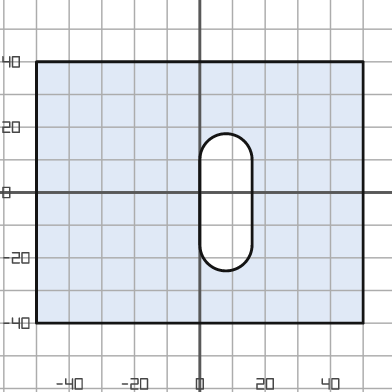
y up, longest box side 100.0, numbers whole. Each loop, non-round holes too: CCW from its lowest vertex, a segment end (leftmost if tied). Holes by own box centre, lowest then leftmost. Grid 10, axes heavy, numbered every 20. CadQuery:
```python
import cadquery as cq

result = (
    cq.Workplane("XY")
    .moveTo(-50.0, -40.0)
    .lineTo(50.0, -40.0)
    .lineTo(50.0, 40.0)
    .lineTo(-50.0, 40.0)
    .close()
    .moveTo(0.0, -16.0)
    .threePointArc((8.0, -24.0), (16.0, -16.0))
    .lineTo(16.0, 10.0)
    .threePointArc((8.0, 18.0), (0.0, 10.0))
    .close()
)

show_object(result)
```